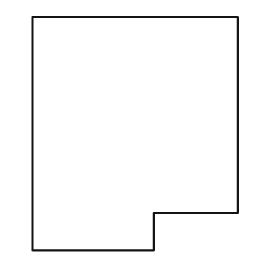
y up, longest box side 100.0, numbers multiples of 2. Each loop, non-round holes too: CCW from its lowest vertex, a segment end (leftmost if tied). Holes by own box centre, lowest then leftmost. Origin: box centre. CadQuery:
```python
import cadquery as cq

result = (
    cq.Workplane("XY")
    .moveTo(-44.0, -50.0)
    .lineTo(8.0, -50.0)
    .lineTo(8.0, -34.0)
    .lineTo(44.0, -34.0)
    .lineTo(44.0, 50.0)
    .lineTo(-44.0, 50.0)
    .close()
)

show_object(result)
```